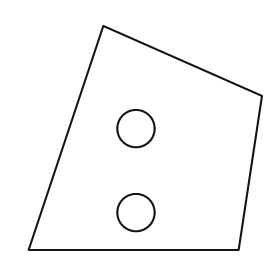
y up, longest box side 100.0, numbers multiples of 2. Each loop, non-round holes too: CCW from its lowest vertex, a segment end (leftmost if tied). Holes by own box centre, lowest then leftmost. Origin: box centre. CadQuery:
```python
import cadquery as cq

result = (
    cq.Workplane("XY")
    .moveTo(-50.0, -48.0)
    .lineTo(40.0, -48.0)
    .lineTo(50.0, 18.0)
    .lineTo(-18.0, 48.0)
    .close()
    .moveTo(-4.0, -32.0)
    .circle(8.0)
    .moveTo(-4.0, 4.0)
    .circle(8.0)
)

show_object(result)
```